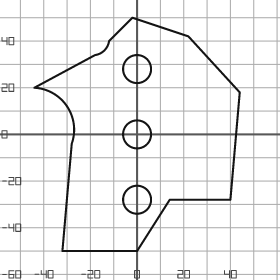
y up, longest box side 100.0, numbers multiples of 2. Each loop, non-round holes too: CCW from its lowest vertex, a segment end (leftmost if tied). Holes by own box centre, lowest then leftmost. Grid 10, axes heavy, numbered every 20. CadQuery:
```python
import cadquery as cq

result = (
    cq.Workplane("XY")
    .moveTo(-32.0, -50.0)
    .lineTo(0.0, -50.0)
    .lineTo(14.0, -28.0)
    .lineTo(40.0, -28.0)
    .lineTo(44.0, 18.0)
    .lineTo(22.0, 42.0)
    .lineTo(-2.0, 50.0)
    .lineTo(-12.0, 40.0)
    .threePointArc((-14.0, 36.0), (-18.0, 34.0))
    .lineTo(-44.0, 20.0)
    .threePointArc((-30.0, 12.0), (-28.0, -4.0))
    .close()
    .moveTo(0.0, -28.0)
    .circle(6.0)
    .moveTo(0.0, 0.0)
    .circle(6.0)
    .moveTo(0.0, 28.0)
    .circle(6.0)
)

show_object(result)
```